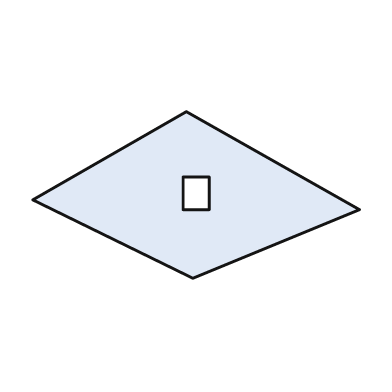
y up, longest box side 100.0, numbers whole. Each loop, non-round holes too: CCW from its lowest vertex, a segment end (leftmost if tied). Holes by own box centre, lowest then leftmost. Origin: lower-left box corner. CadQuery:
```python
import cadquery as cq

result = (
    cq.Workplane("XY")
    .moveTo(49.0, 0.0)
    .lineTo(100.0, 21.0)
    .lineTo(47.0, 51.0)
    .lineTo(0.0, 24.0)
    .close()
    .moveTo(46.0, 21.0)
    .lineTo(54.0, 21.0)
    .lineTo(54.0, 31.0)
    .lineTo(46.0, 31.0)
    .close()
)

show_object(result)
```